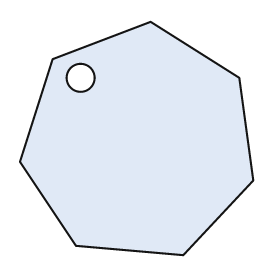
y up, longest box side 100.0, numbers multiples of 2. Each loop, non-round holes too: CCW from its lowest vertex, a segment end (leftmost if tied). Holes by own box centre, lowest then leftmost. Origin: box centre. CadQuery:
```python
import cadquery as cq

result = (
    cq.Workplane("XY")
    .moveTo(20.0, -50.0)
    .lineTo(50.0, -18.0)
    .lineTo(44.0, 26.0)
    .lineTo(6.0, 50.0)
    .lineTo(-36.0, 34.0)
    .lineTo(-50.0, -10.0)
    .lineTo(-26.0, -46.0)
    .close()
    .moveTo(-24.0, 26.0)
    .circle(6.0)
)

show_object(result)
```